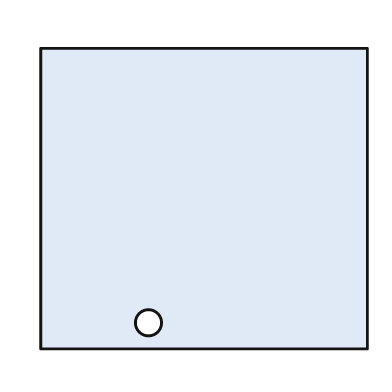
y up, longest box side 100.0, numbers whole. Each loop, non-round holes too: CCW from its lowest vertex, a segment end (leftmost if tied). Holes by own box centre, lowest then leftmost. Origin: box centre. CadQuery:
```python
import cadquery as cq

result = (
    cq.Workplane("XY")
    .moveTo(-50.0, -46.0)
    .lineTo(50.0, -46.0)
    .lineTo(50.0, 46.0)
    .lineTo(-50.0, 46.0)
    .close()
    .moveTo(-17.0, -38.0)
    .circle(4.0)
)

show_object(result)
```